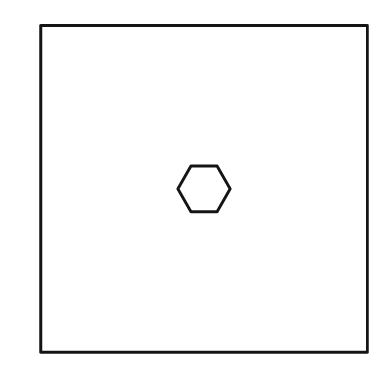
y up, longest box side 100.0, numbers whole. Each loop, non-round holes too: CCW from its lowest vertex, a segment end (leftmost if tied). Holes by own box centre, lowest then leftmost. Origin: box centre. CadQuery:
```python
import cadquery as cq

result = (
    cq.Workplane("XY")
    .moveTo(-50.0, -50.0)
    .lineTo(50.0, -50.0)
    .lineTo(50.0, 50.0)
    .lineTo(-50.0, 50.0)
    .close()
    .moveTo(-4.0, -7.0)
    .lineTo(4.0, -7.0)
    .lineTo(8.0, 0.0)
    .lineTo(4.0, 7.0)
    .lineTo(-4.0, 7.0)
    .lineTo(-8.0, 0.0)
    .close()
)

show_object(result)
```